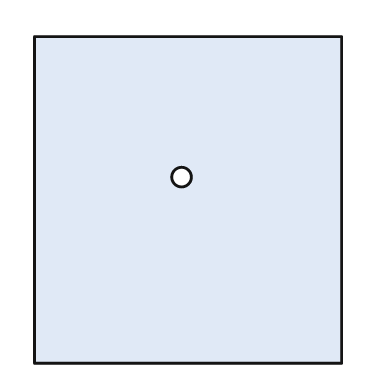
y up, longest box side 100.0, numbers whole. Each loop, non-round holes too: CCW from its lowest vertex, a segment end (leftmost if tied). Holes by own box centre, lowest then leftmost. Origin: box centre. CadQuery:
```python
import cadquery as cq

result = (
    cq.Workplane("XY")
    .moveTo(-47.0, -50.0)
    .lineTo(47.0, -50.0)
    .lineTo(47.0, 50.0)
    .lineTo(-47.0, 50.0)
    .close()
    .moveTo(-2.0, 7.0)
    .circle(3.0)
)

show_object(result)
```